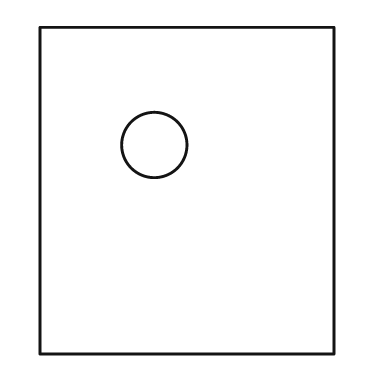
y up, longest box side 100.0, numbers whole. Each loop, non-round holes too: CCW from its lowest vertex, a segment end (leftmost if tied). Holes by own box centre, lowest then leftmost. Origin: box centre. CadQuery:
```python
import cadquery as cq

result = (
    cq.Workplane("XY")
    .moveTo(-45.0, -50.0)
    .lineTo(45.0, -50.0)
    .lineTo(45.0, 50.0)
    .lineTo(-45.0, 50.0)
    .close()
    .moveTo(-10.0, 14.0)
    .circle(10.0)
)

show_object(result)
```